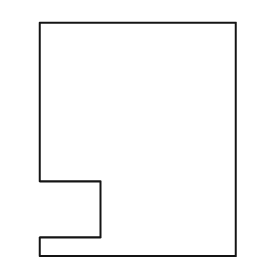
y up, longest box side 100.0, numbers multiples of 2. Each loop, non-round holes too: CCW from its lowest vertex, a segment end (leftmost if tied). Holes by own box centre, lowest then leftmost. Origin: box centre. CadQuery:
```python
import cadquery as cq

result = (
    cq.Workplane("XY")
    .moveTo(-42.0, -50.0)
    .lineTo(42.0, -50.0)
    .lineTo(42.0, 50.0)
    .lineTo(-42.0, 50.0)
    .lineTo(-42.0, -18.0)
    .lineTo(-16.0, -18.0)
    .lineTo(-16.0, -42.0)
    .lineTo(-42.0, -42.0)
    .close()
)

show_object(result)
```